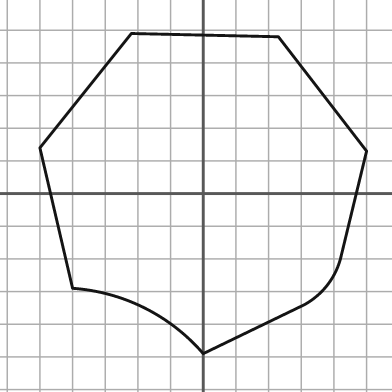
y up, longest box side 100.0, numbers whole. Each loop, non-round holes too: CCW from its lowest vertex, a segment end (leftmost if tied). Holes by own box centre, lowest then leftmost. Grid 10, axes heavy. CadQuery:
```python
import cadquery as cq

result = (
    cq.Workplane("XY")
    .moveTo(0.0, -49.0)
    .lineTo(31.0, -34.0)
    .threePointArc((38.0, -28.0), (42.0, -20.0))
    .lineTo(50.0, 13.0)
    .lineTo(23.0, 48.0)
    .lineTo(-22.0, 49.0)
    .lineTo(-50.0, 14.0)
    .lineTo(-40.0, -29.0)
    .threePointArc((-18.0, -35.0), (0.0, -49.0))
    .close()
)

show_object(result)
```